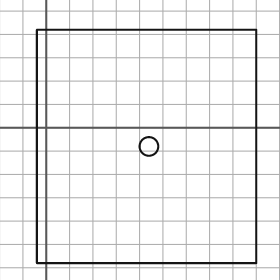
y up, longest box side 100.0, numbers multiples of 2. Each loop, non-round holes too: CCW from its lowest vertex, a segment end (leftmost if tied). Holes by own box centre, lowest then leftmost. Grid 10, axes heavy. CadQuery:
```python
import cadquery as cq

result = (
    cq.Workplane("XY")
    .moveTo(-4.0, -58.0)
    .lineTo(90.0, -58.0)
    .lineTo(90.0, 42.0)
    .lineTo(-4.0, 42.0)
    .close()
    .moveTo(44.0, -8.0)
    .circle(4.0)
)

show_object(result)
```